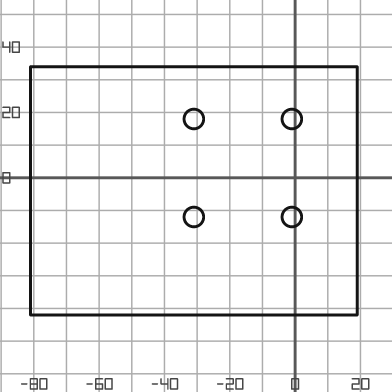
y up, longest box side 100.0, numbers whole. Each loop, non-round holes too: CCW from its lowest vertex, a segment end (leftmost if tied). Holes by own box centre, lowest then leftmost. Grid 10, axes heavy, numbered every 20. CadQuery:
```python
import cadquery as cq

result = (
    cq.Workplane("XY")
    .moveTo(-81.0, -42.0)
    .lineTo(19.0, -42.0)
    .lineTo(19.0, 34.0)
    .lineTo(-81.0, 34.0)
    .close()
    .moveTo(-31.0, -12.0)
    .circle(3.0)
    .moveTo(-1.0, -12.0)
    .circle(3.0)
    .moveTo(-31.0, 18.0)
    .circle(3.0)
    .moveTo(-1.0, 18.0)
    .circle(3.0)
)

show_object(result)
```